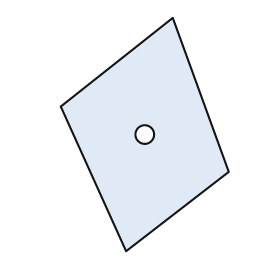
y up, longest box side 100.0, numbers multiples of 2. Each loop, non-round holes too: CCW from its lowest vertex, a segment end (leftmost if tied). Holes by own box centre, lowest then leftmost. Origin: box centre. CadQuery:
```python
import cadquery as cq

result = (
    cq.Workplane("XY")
    .moveTo(-8.0, -50.0)
    .lineTo(36.0, -16.0)
    .lineTo(12.0, 50.0)
    .lineTo(-36.0, 12.0)
    .close()
    .moveTo(0.0, 0.0)
    .circle(4.0)
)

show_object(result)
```